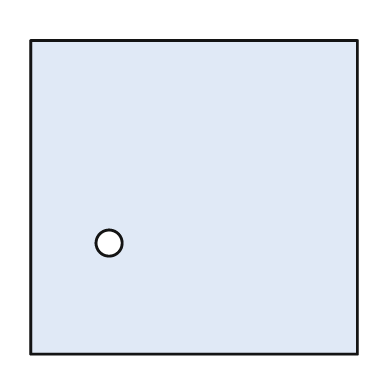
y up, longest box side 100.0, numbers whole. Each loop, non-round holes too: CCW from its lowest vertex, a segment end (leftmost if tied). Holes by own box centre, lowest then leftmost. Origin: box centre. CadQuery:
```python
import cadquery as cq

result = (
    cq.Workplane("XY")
    .moveTo(-50.0, -48.0)
    .lineTo(50.0, -48.0)
    .lineTo(50.0, 48.0)
    .lineTo(-50.0, 48.0)
    .close()
    .moveTo(-26.0, -14.0)
    .circle(4.0)
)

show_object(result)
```